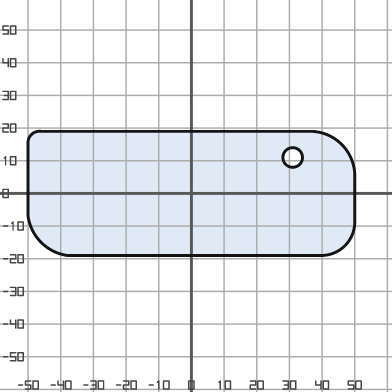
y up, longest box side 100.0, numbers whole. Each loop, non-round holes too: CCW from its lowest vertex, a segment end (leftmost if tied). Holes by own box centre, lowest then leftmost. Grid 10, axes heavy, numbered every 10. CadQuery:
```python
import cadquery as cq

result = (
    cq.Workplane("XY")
    .moveTo(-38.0, -19.0)
    .lineTo(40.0, -19.0)
    .threePointArc((47.0, -16.0), (50.0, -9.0))
    .lineTo(50.0, 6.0)
    .threePointArc((46.0, 15.0), (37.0, 19.0))
    .lineTo(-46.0, 19.0)
    .threePointArc((-49.0, 18.0), (-50.0, 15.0))
    .lineTo(-50.0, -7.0)
    .threePointArc((-46.0, -15.0), (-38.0, -19.0))
    .close()
    .moveTo(31.0, 11.0)
    .circle(3.0)
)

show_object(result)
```